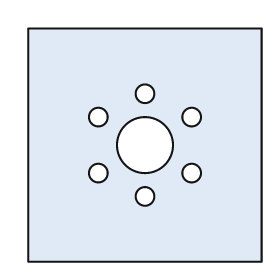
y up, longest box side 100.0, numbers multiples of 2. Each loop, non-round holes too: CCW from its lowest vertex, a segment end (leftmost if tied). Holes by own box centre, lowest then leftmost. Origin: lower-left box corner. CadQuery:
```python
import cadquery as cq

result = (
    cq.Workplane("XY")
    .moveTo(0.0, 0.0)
    .lineTo(100.0, 0.0)
    .lineTo(100.0, 100.0)
    .lineTo(0.0, 100.0)
    .close()
    .moveTo(50.0, 28.0)
    .circle(4.0)
    .moveTo(30.0, 38.0)
    .circle(4.0)
    .moveTo(70.0, 38.0)
    .circle(4.0)
    .moveTo(50.0, 50.0)
    .circle(12.0)
    .moveTo(30.0, 62.0)
    .circle(4.0)
    .moveTo(70.0, 62.0)
    .circle(4.0)
    .moveTo(50.0, 72.0)
    .circle(4.0)
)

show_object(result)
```